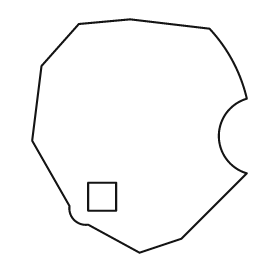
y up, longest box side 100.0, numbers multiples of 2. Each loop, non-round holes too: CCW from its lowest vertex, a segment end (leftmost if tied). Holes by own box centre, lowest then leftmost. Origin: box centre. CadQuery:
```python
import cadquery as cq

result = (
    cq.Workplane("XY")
    .moveTo(0.0, -50.0)
    .lineTo(18.0, -44.0)
    .lineTo(46.0, -16.0)
    .threePointArc((34.0, 0.0), (46.0, 16.0))
    .threePointArc((40.0, 32.0), (30.0, 46.0))
    .lineTo(-4.0, 50.0)
    .lineTo(-26.0, 48.0)
    .lineTo(-42.0, 30.0)
    .lineTo(-46.0, -2.0)
    .lineTo(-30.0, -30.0)
    .threePointArc((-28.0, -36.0), (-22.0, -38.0))
    .close()
    .moveTo(-22.0, -32.0)
    .lineTo(-10.0, -32.0)
    .lineTo(-10.0, -20.0)
    .lineTo(-22.0, -20.0)
    .close()
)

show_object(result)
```